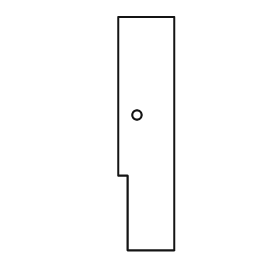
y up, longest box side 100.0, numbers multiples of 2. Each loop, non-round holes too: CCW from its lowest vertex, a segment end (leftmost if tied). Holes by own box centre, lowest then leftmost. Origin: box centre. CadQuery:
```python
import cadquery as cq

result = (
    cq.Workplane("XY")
    .moveTo(-8.0, -50.0)
    .lineTo(12.0, -50.0)
    .lineTo(12.0, 50.0)
    .lineTo(-12.0, 50.0)
    .lineTo(-12.0, -18.0)
    .lineTo(-8.0, -18.0)
    .close()
    .moveTo(-4.0, 8.0)
    .circle(2.0)
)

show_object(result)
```